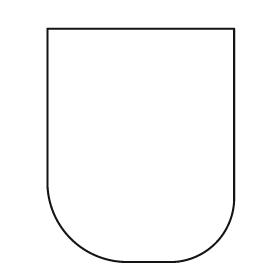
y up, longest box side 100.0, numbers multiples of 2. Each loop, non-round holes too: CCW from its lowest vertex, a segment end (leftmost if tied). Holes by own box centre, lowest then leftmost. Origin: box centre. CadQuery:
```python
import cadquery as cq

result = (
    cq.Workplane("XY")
    .moveTo(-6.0, -50.0)
    .lineTo(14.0, -50.0)
    .threePointArc((32.0, -42.0), (40.0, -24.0))
    .lineTo(40.0, 50.0)
    .lineTo(-40.0, 50.0)
    .lineTo(-40.0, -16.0)
    .threePointArc((-30.0, -40.0), (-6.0, -50.0))
    .close()
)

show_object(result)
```